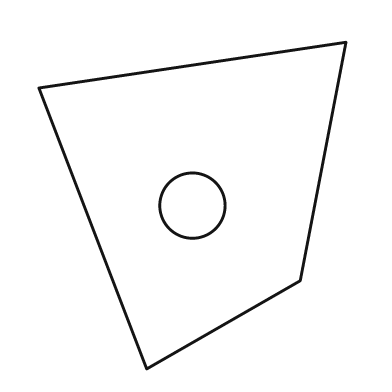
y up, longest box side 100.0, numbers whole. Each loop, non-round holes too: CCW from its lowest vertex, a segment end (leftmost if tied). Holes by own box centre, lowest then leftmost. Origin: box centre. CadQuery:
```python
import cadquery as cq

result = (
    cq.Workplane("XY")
    .moveTo(-14.0, -50.0)
    .lineTo(33.0, -23.0)
    .lineTo(47.0, 50.0)
    .lineTo(-47.0, 36.0)
    .close()
    .moveTo(0.0, 0.0)
    .circle(10.0)
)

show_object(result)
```